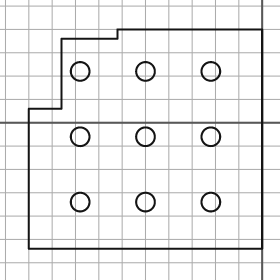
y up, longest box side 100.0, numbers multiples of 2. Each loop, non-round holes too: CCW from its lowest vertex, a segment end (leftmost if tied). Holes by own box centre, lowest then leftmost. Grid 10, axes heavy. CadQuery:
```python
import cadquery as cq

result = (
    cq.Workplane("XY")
    .moveTo(-100.0, -54.0)
    .lineTo(0.0, -54.0)
    .lineTo(0.0, 40.0)
    .lineTo(-62.0, 40.0)
    .lineTo(-62.0, 36.0)
    .lineTo(-86.0, 36.0)
    .lineTo(-86.0, 6.0)
    .lineTo(-100.0, 6.0)
    .close()
    .moveTo(-78.0, -34.0)
    .circle(4.0)
    .moveTo(-50.0, -34.0)
    .circle(4.0)
    .moveTo(-22.0, -34.0)
    .circle(4.0)
    .moveTo(-78.0, -6.0)
    .circle(4.0)
    .moveTo(-50.0, -6.0)
    .circle(4.0)
    .moveTo(-22.0, -6.0)
    .circle(4.0)
    .moveTo(-78.0, 22.0)
    .circle(4.0)
    .moveTo(-50.0, 22.0)
    .circle(4.0)
    .moveTo(-22.0, 22.0)
    .circle(4.0)
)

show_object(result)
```